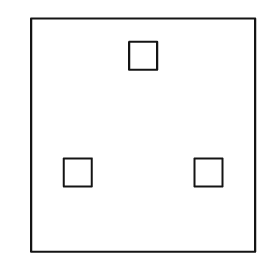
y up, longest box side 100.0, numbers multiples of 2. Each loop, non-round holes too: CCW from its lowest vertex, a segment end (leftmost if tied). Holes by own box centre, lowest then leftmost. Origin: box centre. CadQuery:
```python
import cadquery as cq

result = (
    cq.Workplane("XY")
    .moveTo(-48.0, -50.0)
    .lineTo(48.0, -50.0)
    .lineTo(48.0, 50.0)
    .lineTo(-48.0, 50.0)
    .close()
    .moveTo(-34.0, -22.0)
    .lineTo(-22.0, -22.0)
    .lineTo(-22.0, -10.0)
    .lineTo(-34.0, -10.0)
    .close()
    .moveTo(22.0, -22.0)
    .lineTo(34.0, -22.0)
    .lineTo(34.0, -10.0)
    .lineTo(22.0, -10.0)
    .close()
    .moveTo(-6.0, 28.0)
    .lineTo(6.0, 28.0)
    .lineTo(6.0, 40.0)
    .lineTo(-6.0, 40.0)
    .close()
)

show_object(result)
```